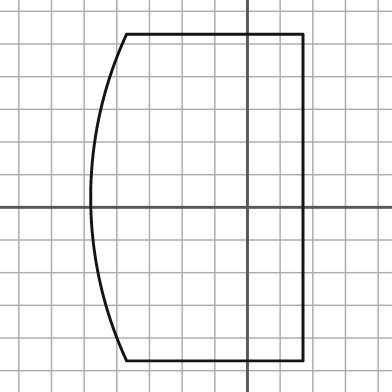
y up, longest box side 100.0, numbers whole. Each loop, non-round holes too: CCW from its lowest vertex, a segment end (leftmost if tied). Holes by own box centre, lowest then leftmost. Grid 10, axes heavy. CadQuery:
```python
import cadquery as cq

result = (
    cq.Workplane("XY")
    .moveTo(-37.0, -47.0)
    .lineTo(17.0, -47.0)
    .lineTo(17.0, 53.0)
    .lineTo(-37.0, 53.0)
    .threePointArc((-48.0, 3.0), (-37.0, -47.0))
    .close()
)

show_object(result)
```